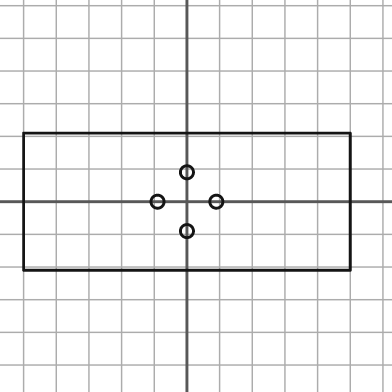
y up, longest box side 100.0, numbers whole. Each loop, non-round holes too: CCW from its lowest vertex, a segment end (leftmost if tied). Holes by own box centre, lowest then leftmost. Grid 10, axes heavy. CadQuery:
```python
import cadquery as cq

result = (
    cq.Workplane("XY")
    .moveTo(-50.0, -21.0)
    .lineTo(50.0, -21.0)
    .lineTo(50.0, 21.0)
    .lineTo(-50.0, 21.0)
    .close()
    .moveTo(0.0, -9.0)
    .circle(2.0)
    .moveTo(-9.0, 0.0)
    .circle(2.0)
    .moveTo(9.0, 0.0)
    .circle(2.0)
    .moveTo(0.0, 9.0)
    .circle(2.0)
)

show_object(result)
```